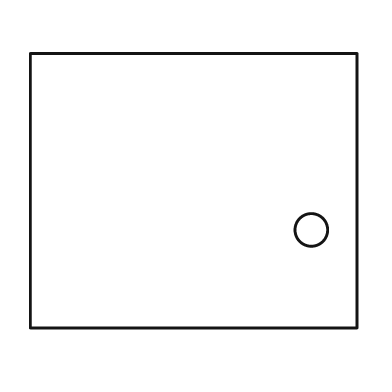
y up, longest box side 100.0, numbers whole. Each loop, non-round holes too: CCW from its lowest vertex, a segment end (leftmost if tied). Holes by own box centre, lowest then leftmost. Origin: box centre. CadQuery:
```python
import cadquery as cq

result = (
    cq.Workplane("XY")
    .moveTo(-50.0, -42.0)
    .lineTo(50.0, -42.0)
    .lineTo(50.0, 42.0)
    .lineTo(-50.0, 42.0)
    .close()
    .moveTo(36.0, -12.0)
    .circle(5.0)
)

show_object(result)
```